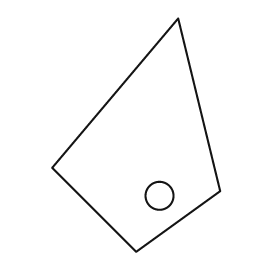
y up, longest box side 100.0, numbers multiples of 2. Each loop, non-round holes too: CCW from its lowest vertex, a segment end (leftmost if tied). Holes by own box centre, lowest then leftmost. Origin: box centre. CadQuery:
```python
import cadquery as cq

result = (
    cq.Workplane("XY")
    .moveTo(0.0, -50.0)
    .lineTo(36.0, -24.0)
    .lineTo(18.0, 50.0)
    .lineTo(-36.0, -14.0)
    .close()
    .moveTo(10.0, -26.0)
    .circle(6.0)
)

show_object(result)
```